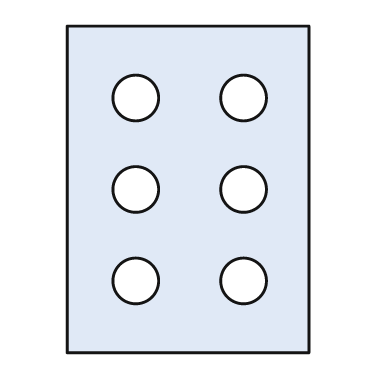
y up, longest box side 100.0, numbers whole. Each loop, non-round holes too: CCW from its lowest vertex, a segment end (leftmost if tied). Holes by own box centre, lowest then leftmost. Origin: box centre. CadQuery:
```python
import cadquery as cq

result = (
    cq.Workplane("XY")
    .moveTo(-37.0, -50.0)
    .lineTo(37.0, -50.0)
    .lineTo(37.0, 50.0)
    .lineTo(-37.0, 50.0)
    .close()
    .moveTo(-16.0, -28.0)
    .circle(7.0)
    .moveTo(17.0, -28.0)
    .circle(7.0)
    .moveTo(-16.0, 0.0)
    .circle(7.0)
    .moveTo(17.0, 0.0)
    .circle(7.0)
    .moveTo(-16.0, 28.0)
    .circle(7.0)
    .moveTo(17.0, 28.0)
    .circle(7.0)
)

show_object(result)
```